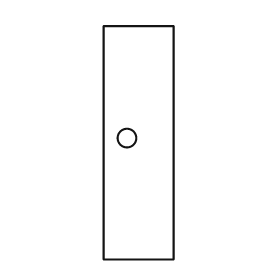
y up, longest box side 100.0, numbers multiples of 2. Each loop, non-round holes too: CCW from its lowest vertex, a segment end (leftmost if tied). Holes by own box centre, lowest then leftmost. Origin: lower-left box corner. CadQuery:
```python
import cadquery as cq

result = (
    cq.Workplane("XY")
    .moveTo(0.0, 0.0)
    .lineTo(30.0, 0.0)
    .lineTo(30.0, 100.0)
    .lineTo(0.0, 100.0)
    .close()
    .moveTo(10.0, 52.0)
    .circle(4.0)
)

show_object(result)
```